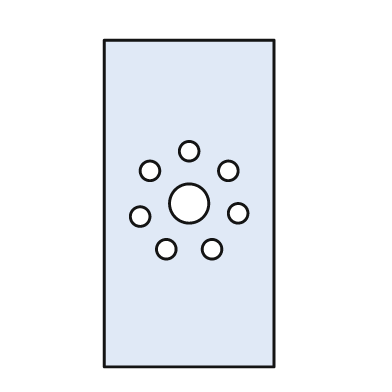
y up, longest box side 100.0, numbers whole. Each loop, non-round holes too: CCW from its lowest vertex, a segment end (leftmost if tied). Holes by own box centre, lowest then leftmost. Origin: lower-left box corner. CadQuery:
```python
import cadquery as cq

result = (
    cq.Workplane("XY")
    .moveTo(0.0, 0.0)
    .lineTo(52.0, 0.0)
    .lineTo(52.0, 100.0)
    .lineTo(0.0, 100.0)
    .close()
    .moveTo(19.0, 36.0)
    .circle(3.0)
    .moveTo(33.0, 36.0)
    .circle(3.0)
    .moveTo(11.0, 46.0)
    .circle(3.0)
    .moveTo(41.0, 47.0)
    .circle(3.0)
    .moveTo(26.0, 50.0)
    .circle(6.0)
    .moveTo(14.0, 60.0)
    .circle(3.0)
    .moveTo(38.0, 60.0)
    .circle(3.0)
    .moveTo(26.0, 66.0)
    .circle(3.0)
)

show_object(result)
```